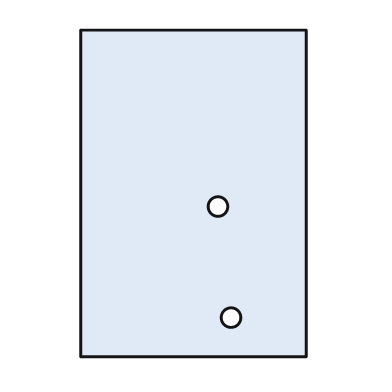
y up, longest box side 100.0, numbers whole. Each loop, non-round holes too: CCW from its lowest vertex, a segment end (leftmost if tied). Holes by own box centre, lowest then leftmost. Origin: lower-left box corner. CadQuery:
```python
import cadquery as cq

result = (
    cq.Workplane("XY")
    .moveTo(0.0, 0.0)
    .lineTo(69.0, 0.0)
    .lineTo(69.0, 100.0)
    .lineTo(0.0, 100.0)
    .close()
    .moveTo(46.0, 12.0)
    .circle(3.0)
    .moveTo(42.0, 46.0)
    .circle(3.0)
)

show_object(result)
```